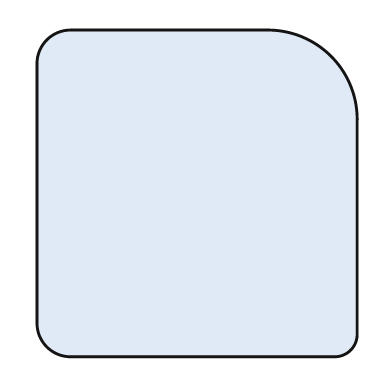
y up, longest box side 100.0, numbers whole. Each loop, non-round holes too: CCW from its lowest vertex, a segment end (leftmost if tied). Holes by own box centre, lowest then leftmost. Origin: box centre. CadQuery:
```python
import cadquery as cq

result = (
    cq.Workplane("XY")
    .moveTo(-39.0, -50.0)
    .lineTo(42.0, -50.0)
    .threePointArc((47.0, -48.0), (49.0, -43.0))
    .lineTo(49.0, 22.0)
    .threePointArc((41.0, 42.0), (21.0, 50.0))
    .lineTo(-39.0, 50.0)
    .threePointArc((-46.0, 47.0), (-49.0, 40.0))
    .lineTo(-49.0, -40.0)
    .threePointArc((-46.0, -47.0), (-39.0, -50.0))
    .close()
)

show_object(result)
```